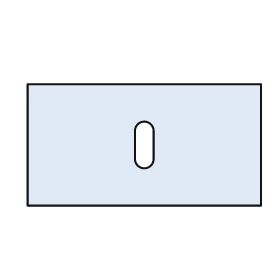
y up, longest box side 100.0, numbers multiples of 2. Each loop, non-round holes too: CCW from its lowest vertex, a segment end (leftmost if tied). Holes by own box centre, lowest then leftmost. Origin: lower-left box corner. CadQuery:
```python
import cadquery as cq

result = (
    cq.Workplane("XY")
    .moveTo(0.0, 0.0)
    .lineTo(100.0, 0.0)
    .lineTo(100.0, 52.0)
    .lineTo(0.0, 52.0)
    .close()
    .moveTo(46.0, 20.0)
    .threePointArc((50.0, 16.0), (54.0, 20.0))
    .lineTo(54.0, 32.0)
    .threePointArc((50.0, 36.0), (46.0, 32.0))
    .close()
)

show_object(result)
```